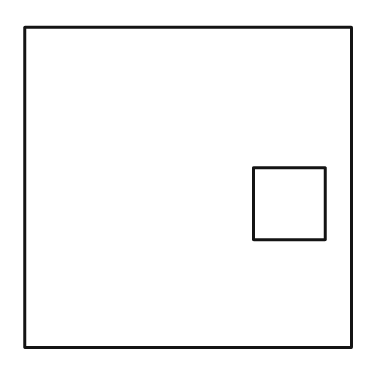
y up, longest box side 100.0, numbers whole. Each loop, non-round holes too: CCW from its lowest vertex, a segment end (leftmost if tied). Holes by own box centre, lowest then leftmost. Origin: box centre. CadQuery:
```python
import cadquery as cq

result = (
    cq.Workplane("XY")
    .moveTo(-50.0, -49.0)
    .lineTo(50.0, -49.0)
    .lineTo(50.0, 49.0)
    .lineTo(-50.0, 49.0)
    .close()
    .moveTo(20.0, -16.0)
    .lineTo(42.0, -16.0)
    .lineTo(42.0, 6.0)
    .lineTo(20.0, 6.0)
    .close()
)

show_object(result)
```